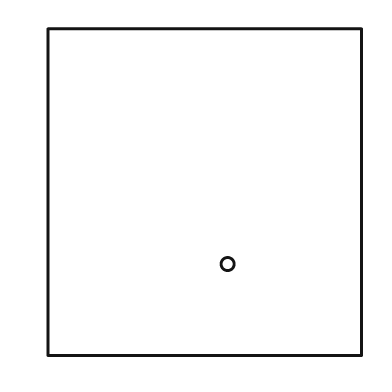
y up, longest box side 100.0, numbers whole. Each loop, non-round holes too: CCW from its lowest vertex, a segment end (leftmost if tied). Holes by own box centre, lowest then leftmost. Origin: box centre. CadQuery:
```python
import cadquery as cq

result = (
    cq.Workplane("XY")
    .moveTo(-48.0, -50.0)
    .lineTo(48.0, -50.0)
    .lineTo(48.0, 50.0)
    .lineTo(-48.0, 50.0)
    .close()
    .moveTo(7.0, -22.0)
    .circle(2.0)
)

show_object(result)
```